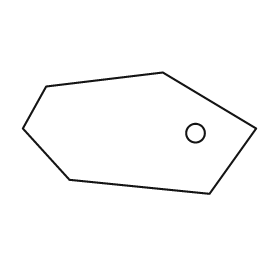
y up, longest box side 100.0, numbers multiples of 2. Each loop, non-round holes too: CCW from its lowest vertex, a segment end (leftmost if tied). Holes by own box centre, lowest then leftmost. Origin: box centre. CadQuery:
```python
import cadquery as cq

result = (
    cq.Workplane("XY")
    .moveTo(30.0, -26.0)
    .lineTo(50.0, 2.0)
    .lineTo(10.0, 26.0)
    .lineTo(-40.0, 20.0)
    .lineTo(-50.0, 2.0)
    .lineTo(-30.0, -20.0)
    .close()
    .moveTo(24.0, 0.0)
    .circle(4.0)
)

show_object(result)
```